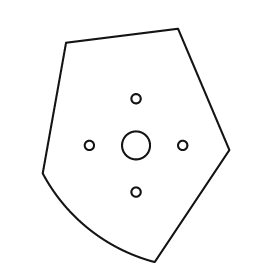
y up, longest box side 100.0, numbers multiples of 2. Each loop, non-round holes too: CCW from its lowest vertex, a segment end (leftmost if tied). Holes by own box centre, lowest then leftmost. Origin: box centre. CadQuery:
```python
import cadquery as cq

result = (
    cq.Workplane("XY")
    .moveTo(8.0, -50.0)
    .lineTo(40.0, -2.0)
    .lineTo(18.0, 50.0)
    .lineTo(-30.0, 44.0)
    .lineTo(-40.0, -12.0)
    .threePointArc((-20.0, -36.0), (8.0, -50.0))
    .close()
    .moveTo(0.0, -20.0)
    .circle(2.0)
    .moveTo(-20.0, 0.0)
    .circle(2.0)
    .moveTo(0.0, 0.0)
    .circle(6.0)
    .moveTo(20.0, 0.0)
    .circle(2.0)
    .moveTo(0.0, 20.0)
    .circle(2.0)
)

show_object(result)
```